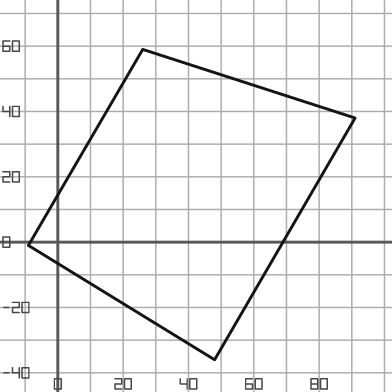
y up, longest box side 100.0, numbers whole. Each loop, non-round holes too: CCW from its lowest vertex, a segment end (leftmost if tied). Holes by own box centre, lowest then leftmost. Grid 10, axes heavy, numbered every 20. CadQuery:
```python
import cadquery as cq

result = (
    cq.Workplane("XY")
    .moveTo(48.0, -36.0)
    .lineTo(91.0, 38.0)
    .lineTo(26.0, 59.0)
    .lineTo(-9.0, -1.0)
    .close()
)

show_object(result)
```